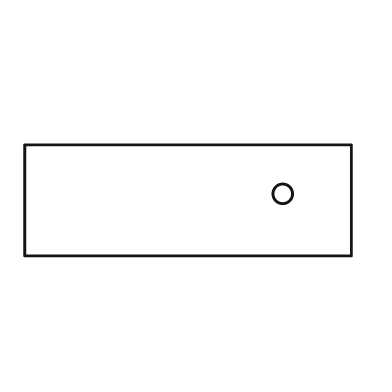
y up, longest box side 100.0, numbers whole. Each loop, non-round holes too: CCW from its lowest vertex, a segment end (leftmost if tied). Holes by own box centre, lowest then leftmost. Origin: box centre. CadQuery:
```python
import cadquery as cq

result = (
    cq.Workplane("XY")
    .moveTo(-50.0, -17.0)
    .lineTo(50.0, -17.0)
    .lineTo(50.0, 17.0)
    .lineTo(-50.0, 17.0)
    .close()
    .moveTo(29.0, 2.0)
    .circle(3.0)
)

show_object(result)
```